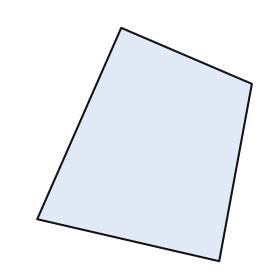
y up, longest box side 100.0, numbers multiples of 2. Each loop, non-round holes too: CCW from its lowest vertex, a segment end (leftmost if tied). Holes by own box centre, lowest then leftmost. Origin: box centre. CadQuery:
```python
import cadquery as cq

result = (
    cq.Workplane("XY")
    .moveTo(32.0, -50.0)
    .lineTo(46.0, 26.0)
    .lineTo(-10.0, 50.0)
    .lineTo(-46.0, -32.0)
    .close()
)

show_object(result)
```